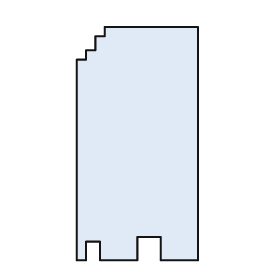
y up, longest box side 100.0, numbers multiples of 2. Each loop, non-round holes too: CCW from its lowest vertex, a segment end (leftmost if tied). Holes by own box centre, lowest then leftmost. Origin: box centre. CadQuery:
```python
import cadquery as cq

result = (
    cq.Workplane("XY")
    .moveTo(-26.0, -50.0)
    .lineTo(-22.0, -50.0)
    .lineTo(-22.0, -42.0)
    .lineTo(-16.0, -42.0)
    .lineTo(-16.0, -50.0)
    .lineTo(0.0, -50.0)
    .lineTo(0.0, -40.0)
    .lineTo(10.0, -40.0)
    .lineTo(10.0, -50.0)
    .lineTo(26.0, -50.0)
    .lineTo(26.0, 50.0)
    .lineTo(-14.0, 50.0)
    .lineTo(-14.0, 46.0)
    .lineTo(-18.0, 46.0)
    .lineTo(-18.0, 40.0)
    .lineTo(-22.0, 40.0)
    .lineTo(-22.0, 36.0)
    .lineTo(-26.0, 36.0)
    .close()
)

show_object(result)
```